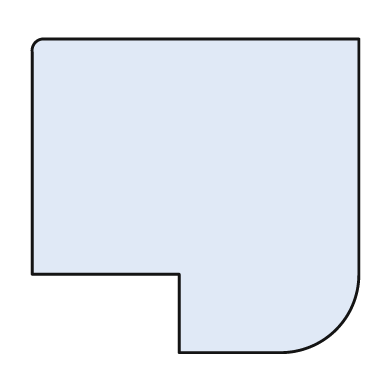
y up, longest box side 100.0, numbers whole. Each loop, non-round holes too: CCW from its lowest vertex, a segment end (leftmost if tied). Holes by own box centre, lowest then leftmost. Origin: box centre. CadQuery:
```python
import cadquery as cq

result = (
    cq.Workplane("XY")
    .moveTo(-5.0, -48.0)
    .lineTo(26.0, -48.0)
    .threePointArc((43.0, -41.0), (50.0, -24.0))
    .lineTo(50.0, 48.0)
    .lineTo(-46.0, 48.0)
    .threePointArc((-49.0, 47.0), (-50.0, 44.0))
    .lineTo(-50.0, -24.0)
    .lineTo(-5.0, -24.0)
    .close()
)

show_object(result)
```